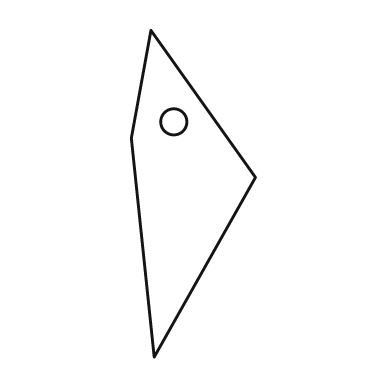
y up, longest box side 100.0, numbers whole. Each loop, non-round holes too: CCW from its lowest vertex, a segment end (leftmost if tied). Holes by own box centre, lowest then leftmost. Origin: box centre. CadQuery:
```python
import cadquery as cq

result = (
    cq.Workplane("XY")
    .moveTo(-12.0, -50.0)
    .lineTo(19.0, 5.0)
    .lineTo(-13.0, 50.0)
    .lineTo(-19.0, 17.0)
    .close()
    .moveTo(-6.0, 22.0)
    .circle(4.0)
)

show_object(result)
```